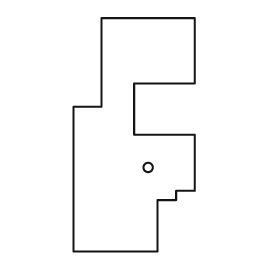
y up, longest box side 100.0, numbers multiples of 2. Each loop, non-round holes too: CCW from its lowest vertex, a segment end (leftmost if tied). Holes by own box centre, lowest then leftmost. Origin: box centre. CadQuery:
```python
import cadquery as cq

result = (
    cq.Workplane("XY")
    .moveTo(-26.0, -50.0)
    .lineTo(10.0, -50.0)
    .lineTo(10.0, -28.0)
    .lineTo(18.0, -28.0)
    .lineTo(18.0, -24.0)
    .lineTo(26.0, -24.0)
    .lineTo(26.0, 0.0)
    .lineTo(0.0, 0.0)
    .lineTo(0.0, 22.0)
    .lineTo(26.0, 22.0)
    .lineTo(26.0, 50.0)
    .lineTo(-14.0, 50.0)
    .lineTo(-14.0, 12.0)
    .lineTo(-26.0, 12.0)
    .close()
    .moveTo(6.0, -14.0)
    .circle(2.0)
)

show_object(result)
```